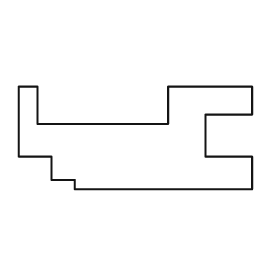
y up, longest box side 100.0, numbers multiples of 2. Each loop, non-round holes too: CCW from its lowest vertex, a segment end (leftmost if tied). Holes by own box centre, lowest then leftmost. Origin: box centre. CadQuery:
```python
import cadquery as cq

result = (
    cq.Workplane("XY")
    .moveTo(-26.0, -22.0)
    .lineTo(50.0, -22.0)
    .lineTo(50.0, -8.0)
    .lineTo(30.0, -8.0)
    .lineTo(30.0, 10.0)
    .lineTo(50.0, 10.0)
    .lineTo(50.0, 22.0)
    .lineTo(14.0, 22.0)
    .lineTo(14.0, 6.0)
    .lineTo(-42.0, 6.0)
    .lineTo(-42.0, 22.0)
    .lineTo(-50.0, 22.0)
    .lineTo(-50.0, -8.0)
    .lineTo(-36.0, -8.0)
    .lineTo(-36.0, -18.0)
    .lineTo(-26.0, -18.0)
    .close()
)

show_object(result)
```